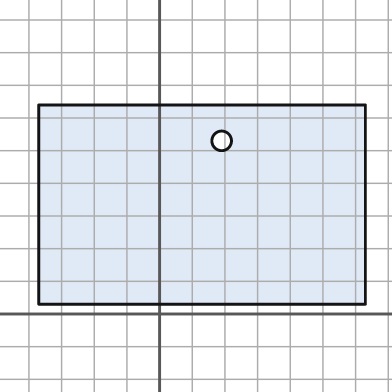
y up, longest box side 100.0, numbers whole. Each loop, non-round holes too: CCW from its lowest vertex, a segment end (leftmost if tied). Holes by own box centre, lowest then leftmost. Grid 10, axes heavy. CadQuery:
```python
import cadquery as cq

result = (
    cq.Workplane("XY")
    .moveTo(-37.0, 3.0)
    .lineTo(63.0, 3.0)
    .lineTo(63.0, 64.0)
    .lineTo(-37.0, 64.0)
    .close()
    .moveTo(19.0, 53.0)
    .circle(3.0)
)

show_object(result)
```